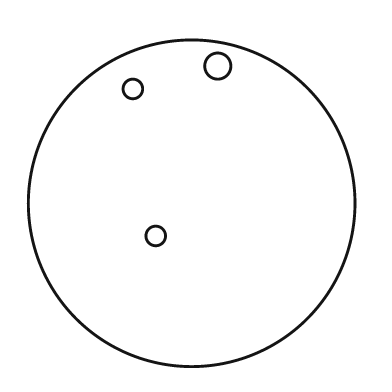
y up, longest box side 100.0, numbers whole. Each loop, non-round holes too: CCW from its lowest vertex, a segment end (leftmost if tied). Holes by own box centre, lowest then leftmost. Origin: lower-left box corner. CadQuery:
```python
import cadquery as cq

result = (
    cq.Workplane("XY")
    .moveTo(50.0, 50.0)
    .circle(50.0)
    .moveTo(39.0, 40.0)
    .circle(3.0)
    .moveTo(32.0, 85.0)
    .circle(3.0)
    .moveTo(58.0, 92.0)
    .circle(4.0)
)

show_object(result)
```